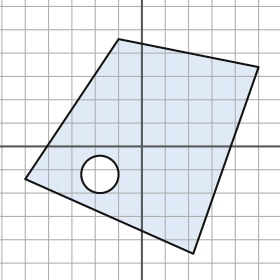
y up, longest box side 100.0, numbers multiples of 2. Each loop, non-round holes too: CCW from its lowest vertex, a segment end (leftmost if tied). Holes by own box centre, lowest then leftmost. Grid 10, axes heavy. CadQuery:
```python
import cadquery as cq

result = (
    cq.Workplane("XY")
    .moveTo(22.0, -46.0)
    .lineTo(50.0, 34.0)
    .lineTo(-10.0, 46.0)
    .lineTo(-50.0, -14.0)
    .close()
    .moveTo(-18.0, -12.0)
    .circle(8.0)
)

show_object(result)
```